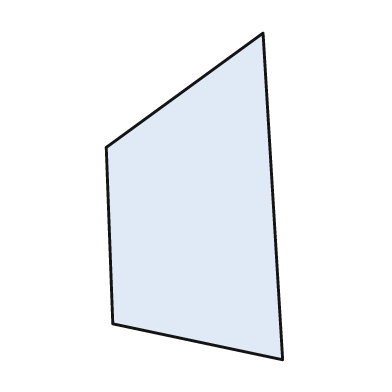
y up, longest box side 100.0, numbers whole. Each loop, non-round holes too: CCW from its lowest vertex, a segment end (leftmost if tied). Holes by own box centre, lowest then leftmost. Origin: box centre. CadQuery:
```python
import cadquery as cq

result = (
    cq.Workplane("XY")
    .moveTo(27.0, -50.0)
    .lineTo(21.0, 50.0)
    .lineTo(-27.0, 15.0)
    .lineTo(-25.0, -39.0)
    .close()
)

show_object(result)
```